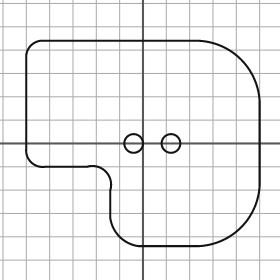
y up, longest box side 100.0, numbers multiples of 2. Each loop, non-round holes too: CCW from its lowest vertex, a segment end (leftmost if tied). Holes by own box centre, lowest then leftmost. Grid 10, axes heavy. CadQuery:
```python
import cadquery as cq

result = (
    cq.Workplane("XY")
    .moveTo(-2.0, -44.0)
    .lineTo(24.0, -44.0)
    .threePointArc((42.0, -36.0), (50.0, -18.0))
    .lineTo(50.0, 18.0)
    .threePointArc((42.0, 36.0), (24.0, 44.0))
    .lineTo(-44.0, 44.0)
    .threePointArc((-48.0, 42.0), (-50.0, 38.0))
    .lineTo(-50.0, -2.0)
    .threePointArc((-48.0, -8.0), (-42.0, -10.0))
    .lineTo(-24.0, -10.0)
    .threePointArc((-16.0, -12.0), (-14.0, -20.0))
    .lineTo(-14.0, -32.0)
    .threePointArc((-10.0, -40.0), (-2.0, -44.0))
    .close()
    .moveTo(-4.0, 0.0)
    .circle(4.0)
    .moveTo(12.0, 0.0)
    .circle(4.0)
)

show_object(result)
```